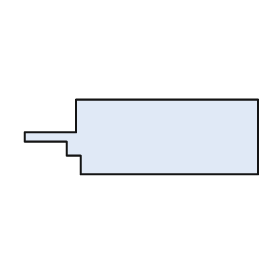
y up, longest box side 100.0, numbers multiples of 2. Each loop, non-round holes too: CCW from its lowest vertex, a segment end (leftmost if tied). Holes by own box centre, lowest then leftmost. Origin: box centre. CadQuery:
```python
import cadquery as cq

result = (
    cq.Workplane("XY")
    .moveTo(-26.0, -16.0)
    .lineTo(50.0, -16.0)
    .lineTo(50.0, 16.0)
    .lineTo(-28.0, 16.0)
    .lineTo(-28.0, 2.0)
    .lineTo(-50.0, 2.0)
    .lineTo(-50.0, -2.0)
    .lineTo(-32.0, -2.0)
    .lineTo(-32.0, -8.0)
    .lineTo(-26.0, -8.0)
    .close()
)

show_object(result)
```